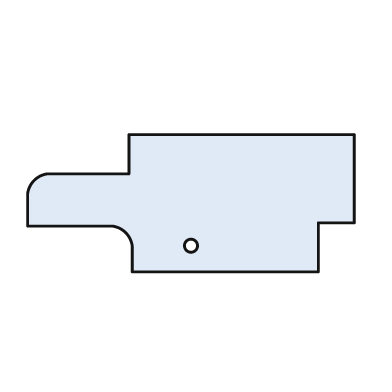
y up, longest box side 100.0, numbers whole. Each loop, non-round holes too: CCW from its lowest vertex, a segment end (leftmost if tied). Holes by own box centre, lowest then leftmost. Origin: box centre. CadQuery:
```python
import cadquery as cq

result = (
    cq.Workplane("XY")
    .moveTo(-18.0, -21.0)
    .lineTo(39.0, -21.0)
    .lineTo(39.0, -6.0)
    .lineTo(50.0, -6.0)
    .lineTo(50.0, 21.0)
    .lineTo(-19.0, 21.0)
    .lineTo(-19.0, 9.0)
    .lineTo(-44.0, 9.0)
    .threePointArc((-48.0, 7.0), (-50.0, 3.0))
    .lineTo(-50.0, -7.0)
    .lineTo(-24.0, -7.0)
    .threePointArc((-20.0, -9.0), (-18.0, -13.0))
    .close()
    .moveTo(0.0, -13.0)
    .circle(2.0)
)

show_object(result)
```